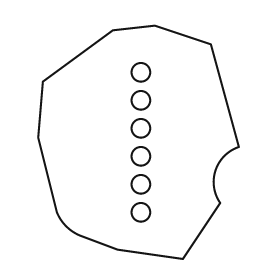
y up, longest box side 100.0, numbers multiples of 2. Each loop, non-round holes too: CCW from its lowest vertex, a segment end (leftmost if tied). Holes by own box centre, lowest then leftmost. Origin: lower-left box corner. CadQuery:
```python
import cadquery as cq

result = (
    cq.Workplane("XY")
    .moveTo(62.0, 0.0)
    .lineTo(78.0, 24.0)
    .threePointArc((76.0, 38.0), (86.0, 48.0))
    .lineTo(74.0, 92.0)
    .lineTo(50.0, 100.0)
    .lineTo(32.0, 98.0)
    .lineTo(2.0, 76.0)
    .lineTo(0.0, 52.0)
    .lineTo(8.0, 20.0)
    .threePointArc((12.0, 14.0), (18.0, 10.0))
    .lineTo(34.0, 4.0)
    .close()
    .moveTo(44.0, 20.0)
    .circle(4.0)
    .moveTo(44.0, 32.0)
    .circle(4.0)
    .moveTo(44.0, 44.0)
    .circle(4.0)
    .moveTo(44.0, 56.0)
    .circle(4.0)
    .moveTo(44.0, 68.0)
    .circle(4.0)
    .moveTo(44.0, 80.0)
    .circle(4.0)
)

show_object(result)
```